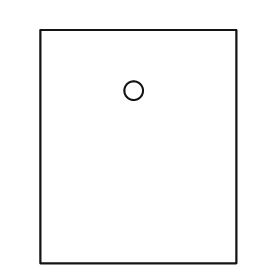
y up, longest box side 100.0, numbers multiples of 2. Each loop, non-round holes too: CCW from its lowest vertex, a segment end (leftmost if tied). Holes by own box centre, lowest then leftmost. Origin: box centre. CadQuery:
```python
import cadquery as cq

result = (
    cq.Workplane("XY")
    .moveTo(-42.0, -50.0)
    .lineTo(42.0, -50.0)
    .lineTo(42.0, 50.0)
    .lineTo(-42.0, 50.0)
    .close()
    .moveTo(-2.0, 24.0)
    .circle(4.0)
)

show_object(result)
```